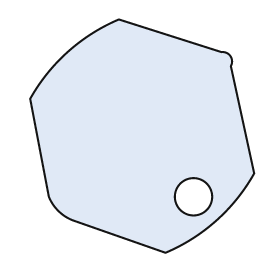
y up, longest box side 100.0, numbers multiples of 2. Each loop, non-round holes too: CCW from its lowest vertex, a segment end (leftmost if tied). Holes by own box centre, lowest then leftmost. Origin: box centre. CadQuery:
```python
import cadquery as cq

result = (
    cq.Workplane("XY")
    .moveTo(10.0, -50.0)
    .threePointArc((32.0, -36.0), (48.0, -16.0))
    .lineTo(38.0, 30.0)
    .threePointArc((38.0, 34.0), (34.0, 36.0))
    .lineTo(-10.0, 50.0)
    .threePointArc((-32.0, 36.0), (-48.0, 16.0))
    .lineTo(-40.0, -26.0)
    .threePointArc((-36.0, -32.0), (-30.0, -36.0))
    .close()
    .moveTo(22.0, -26.0)
    .circle(8.0)
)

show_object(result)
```